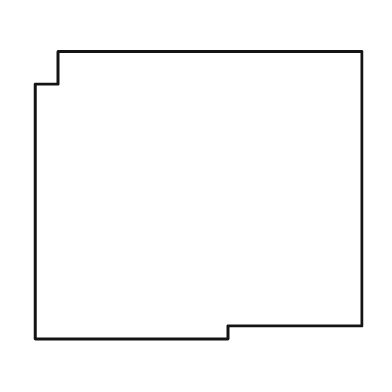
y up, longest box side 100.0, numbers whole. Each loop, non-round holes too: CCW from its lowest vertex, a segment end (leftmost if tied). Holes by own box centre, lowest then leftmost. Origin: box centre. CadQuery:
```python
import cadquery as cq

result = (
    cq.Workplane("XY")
    .moveTo(-50.0, -44.0)
    .lineTo(9.0, -44.0)
    .lineTo(9.0, -40.0)
    .lineTo(50.0, -40.0)
    .lineTo(50.0, 44.0)
    .lineTo(-43.0, 44.0)
    .lineTo(-43.0, 34.0)
    .lineTo(-50.0, 34.0)
    .close()
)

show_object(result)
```